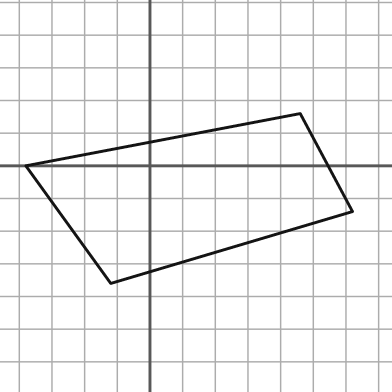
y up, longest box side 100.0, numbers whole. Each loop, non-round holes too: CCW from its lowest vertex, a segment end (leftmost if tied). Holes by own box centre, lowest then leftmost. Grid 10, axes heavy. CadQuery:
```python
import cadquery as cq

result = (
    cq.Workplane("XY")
    .moveTo(-12.0, -36.0)
    .lineTo(62.0, -14.0)
    .lineTo(46.0, 16.0)
    .lineTo(-38.0, 0.0)
    .close()
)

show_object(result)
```